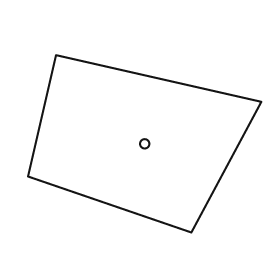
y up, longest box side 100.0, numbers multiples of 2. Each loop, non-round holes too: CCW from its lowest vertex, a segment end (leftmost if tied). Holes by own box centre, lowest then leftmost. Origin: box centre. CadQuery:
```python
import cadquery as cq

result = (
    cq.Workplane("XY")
    .moveTo(20.0, -38.0)
    .lineTo(50.0, 18.0)
    .lineTo(-38.0, 38.0)
    .lineTo(-50.0, -14.0)
    .close()
    .moveTo(0.0, 0.0)
    .circle(2.0)
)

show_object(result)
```